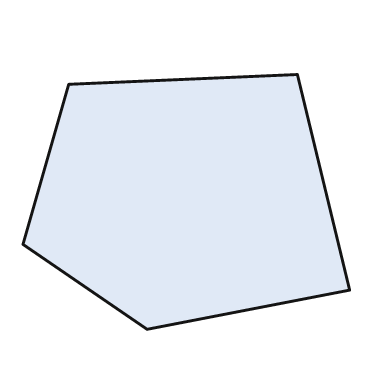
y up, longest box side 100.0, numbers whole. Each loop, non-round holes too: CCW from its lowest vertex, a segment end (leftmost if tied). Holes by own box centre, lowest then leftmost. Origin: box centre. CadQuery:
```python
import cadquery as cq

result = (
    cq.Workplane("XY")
    .moveTo(-12.0, -39.0)
    .lineTo(50.0, -27.0)
    .lineTo(34.0, 39.0)
    .lineTo(-36.0, 36.0)
    .lineTo(-50.0, -13.0)
    .close()
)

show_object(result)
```